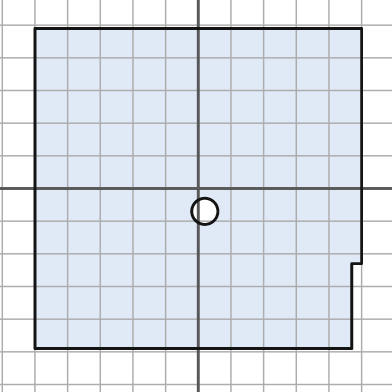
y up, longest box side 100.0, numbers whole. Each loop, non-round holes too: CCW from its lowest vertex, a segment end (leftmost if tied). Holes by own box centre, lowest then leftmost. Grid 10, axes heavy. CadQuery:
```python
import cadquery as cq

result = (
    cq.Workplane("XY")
    .moveTo(-50.0, -49.0)
    .lineTo(47.0, -49.0)
    .lineTo(47.0, -23.0)
    .lineTo(50.0, -23.0)
    .lineTo(50.0, 49.0)
    .lineTo(-50.0, 49.0)
    .close()
    .moveTo(2.0, -7.0)
    .circle(4.0)
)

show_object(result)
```